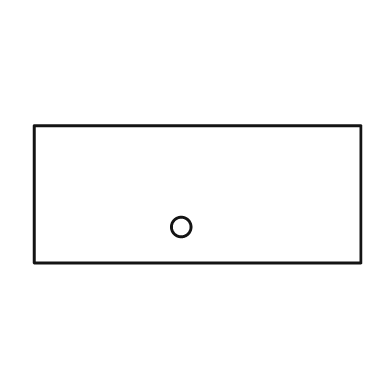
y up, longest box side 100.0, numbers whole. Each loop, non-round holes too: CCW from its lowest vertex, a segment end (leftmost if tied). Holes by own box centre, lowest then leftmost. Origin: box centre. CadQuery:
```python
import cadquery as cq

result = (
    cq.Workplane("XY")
    .moveTo(-50.0, -21.0)
    .lineTo(50.0, -21.0)
    .lineTo(50.0, 21.0)
    .lineTo(-50.0, 21.0)
    .close()
    .moveTo(-5.0, -10.0)
    .circle(3.0)
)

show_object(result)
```